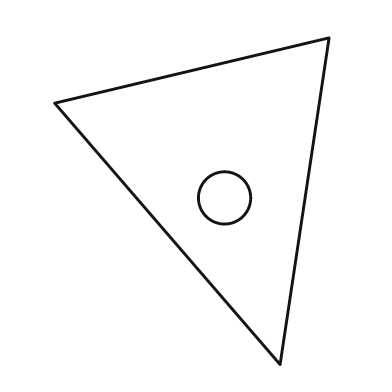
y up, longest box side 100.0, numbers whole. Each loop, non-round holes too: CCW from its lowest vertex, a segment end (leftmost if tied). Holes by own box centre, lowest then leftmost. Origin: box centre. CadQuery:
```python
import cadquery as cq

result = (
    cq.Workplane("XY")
    .moveTo(27.0, -50.0)
    .lineTo(42.0, 50.0)
    .lineTo(-42.0, 30.0)
    .close()
    .moveTo(10.0, 1.0)
    .circle(8.0)
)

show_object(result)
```